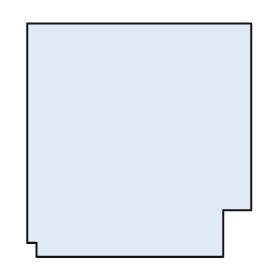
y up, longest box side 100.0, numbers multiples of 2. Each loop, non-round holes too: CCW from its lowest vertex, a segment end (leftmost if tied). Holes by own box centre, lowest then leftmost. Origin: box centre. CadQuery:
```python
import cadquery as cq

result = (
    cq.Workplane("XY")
    .moveTo(-44.0, -50.0)
    .lineTo(36.0, -50.0)
    .lineTo(36.0, -30.0)
    .lineTo(48.0, -30.0)
    .lineTo(48.0, 50.0)
    .lineTo(-48.0, 50.0)
    .lineTo(-48.0, -44.0)
    .lineTo(-44.0, -44.0)
    .close()
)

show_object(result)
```